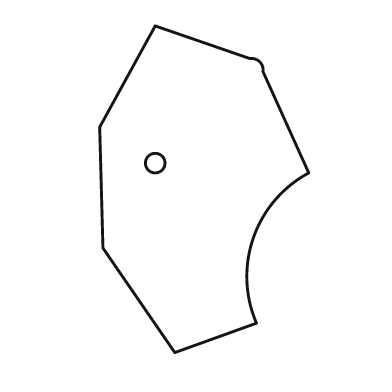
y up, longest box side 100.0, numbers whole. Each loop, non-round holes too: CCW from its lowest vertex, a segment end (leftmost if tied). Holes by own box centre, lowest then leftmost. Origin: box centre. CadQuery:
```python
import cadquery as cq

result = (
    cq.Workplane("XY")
    .moveTo(-9.0, -50.0)
    .lineTo(16.0, -41.0)
    .threePointArc((15.0, -15.0), (32.0, 5.0))
    .lineTo(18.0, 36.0)
    .threePointArc((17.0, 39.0), (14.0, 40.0))
    .lineTo(-15.0, 50.0)
    .lineTo(-32.0, 19.0)
    .lineTo(-31.0, -18.0)
    .close()
    .moveTo(-15.0, 8.0)
    .circle(3.0)
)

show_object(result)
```